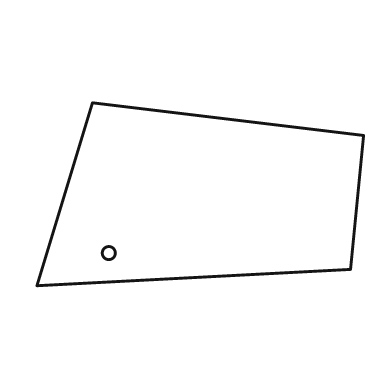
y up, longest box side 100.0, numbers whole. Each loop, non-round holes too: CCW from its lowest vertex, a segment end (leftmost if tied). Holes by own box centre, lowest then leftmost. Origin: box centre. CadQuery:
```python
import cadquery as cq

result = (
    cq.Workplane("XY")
    .moveTo(-50.0, -28.0)
    .lineTo(46.0, -23.0)
    .lineTo(50.0, 18.0)
    .lineTo(-33.0, 28.0)
    .close()
    .moveTo(-28.0, -18.0)
    .circle(2.0)
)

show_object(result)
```